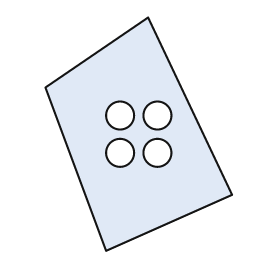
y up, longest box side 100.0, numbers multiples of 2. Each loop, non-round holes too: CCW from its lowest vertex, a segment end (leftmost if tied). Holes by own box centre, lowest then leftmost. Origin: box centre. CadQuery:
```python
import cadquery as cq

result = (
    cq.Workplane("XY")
    .moveTo(-14.0, -50.0)
    .lineTo(40.0, -26.0)
    .lineTo(4.0, 50.0)
    .lineTo(-40.0, 20.0)
    .close()
    .moveTo(-8.0, -8.0)
    .circle(6.0)
    .moveTo(8.0, -8.0)
    .circle(6.0)
    .moveTo(-8.0, 8.0)
    .circle(6.0)
    .moveTo(8.0, 8.0)
    .circle(6.0)
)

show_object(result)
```